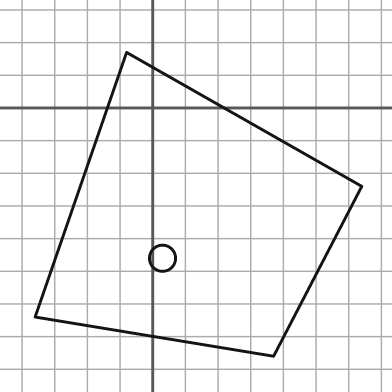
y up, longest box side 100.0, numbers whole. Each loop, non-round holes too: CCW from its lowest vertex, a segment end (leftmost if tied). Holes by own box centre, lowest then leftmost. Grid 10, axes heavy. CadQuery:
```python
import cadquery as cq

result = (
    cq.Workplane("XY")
    .moveTo(37.0, -76.0)
    .lineTo(64.0, -24.0)
    .lineTo(-8.0, 17.0)
    .lineTo(-36.0, -64.0)
    .close()
    .moveTo(3.0, -46.0)
    .circle(4.0)
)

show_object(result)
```